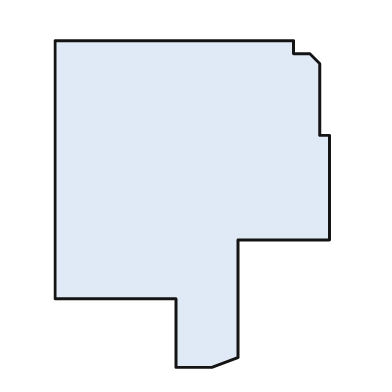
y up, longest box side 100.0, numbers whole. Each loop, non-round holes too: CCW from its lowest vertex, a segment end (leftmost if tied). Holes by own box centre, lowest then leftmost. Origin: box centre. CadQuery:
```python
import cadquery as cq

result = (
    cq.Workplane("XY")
    .moveTo(-5.0, -50.0)
    .lineTo(6.0, -50.0)
    .lineTo(14.0, -47.0)
    .lineTo(14.0, -11.0)
    .lineTo(42.0, -11.0)
    .lineTo(42.0, 21.0)
    .lineTo(39.0, 21.0)
    .lineTo(39.0, 43.0)
    .lineTo(36.0, 46.0)
    .lineTo(31.0, 46.0)
    .lineTo(31.0, 50.0)
    .lineTo(-42.0, 50.0)
    .lineTo(-42.0, -29.0)
    .lineTo(-5.0, -29.0)
    .close()
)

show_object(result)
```